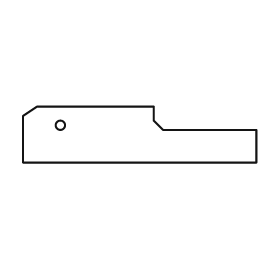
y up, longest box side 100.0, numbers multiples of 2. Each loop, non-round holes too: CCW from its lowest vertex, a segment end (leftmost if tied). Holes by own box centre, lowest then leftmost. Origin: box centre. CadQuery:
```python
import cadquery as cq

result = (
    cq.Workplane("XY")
    .moveTo(-50.0, -12.0)
    .lineTo(50.0, -12.0)
    .lineTo(50.0, 2.0)
    .lineTo(10.0, 2.0)
    .lineTo(6.0, 6.0)
    .lineTo(6.0, 12.0)
    .lineTo(-44.0, 12.0)
    .lineTo(-50.0, 8.0)
    .close()
    .moveTo(-34.0, 4.0)
    .circle(2.0)
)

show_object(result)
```